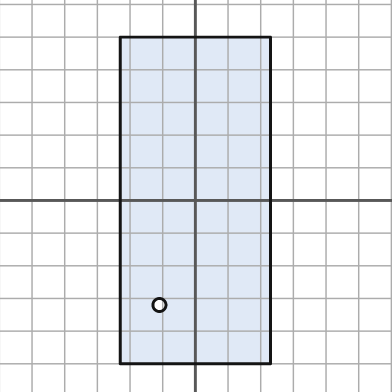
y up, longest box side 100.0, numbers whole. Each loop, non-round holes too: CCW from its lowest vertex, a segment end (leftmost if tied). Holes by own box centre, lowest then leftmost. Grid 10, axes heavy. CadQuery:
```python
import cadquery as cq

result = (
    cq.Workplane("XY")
    .moveTo(-23.0, -50.0)
    .lineTo(23.0, -50.0)
    .lineTo(23.0, 50.0)
    .lineTo(-23.0, 50.0)
    .close()
    .moveTo(-11.0, -32.0)
    .circle(2.0)
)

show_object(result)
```